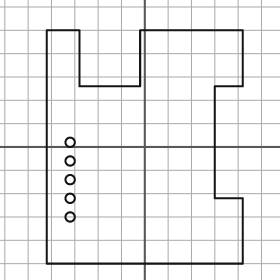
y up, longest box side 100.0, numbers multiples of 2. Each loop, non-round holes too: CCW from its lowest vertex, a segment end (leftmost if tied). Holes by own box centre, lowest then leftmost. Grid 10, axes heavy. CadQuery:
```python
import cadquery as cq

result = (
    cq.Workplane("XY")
    .moveTo(-42.0, -50.0)
    .lineTo(42.0, -50.0)
    .lineTo(42.0, -22.0)
    .lineTo(30.0, -22.0)
    .lineTo(30.0, 26.0)
    .lineTo(42.0, 26.0)
    .lineTo(42.0, 50.0)
    .lineTo(-2.0, 50.0)
    .lineTo(-2.0, 26.0)
    .lineTo(-28.0, 26.0)
    .lineTo(-28.0, 50.0)
    .lineTo(-42.0, 50.0)
    .close()
    .moveTo(-32.0, -30.0)
    .circle(2.0)
    .moveTo(-32.0, -22.0)
    .circle(2.0)
    .moveTo(-32.0, -14.0)
    .circle(2.0)
    .moveTo(-32.0, -6.0)
    .circle(2.0)
    .moveTo(-32.0, 2.0)
    .circle(2.0)
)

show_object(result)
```